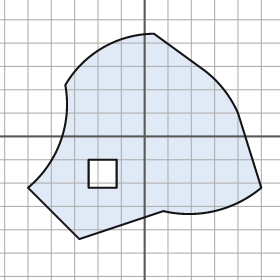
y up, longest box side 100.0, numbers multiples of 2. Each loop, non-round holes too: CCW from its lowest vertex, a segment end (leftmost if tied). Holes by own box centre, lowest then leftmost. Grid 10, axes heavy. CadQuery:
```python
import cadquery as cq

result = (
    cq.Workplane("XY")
    .moveTo(-28.0, -44.0)
    .lineTo(8.0, -32.0)
    .threePointArc((30.0, -32.0), (50.0, -22.0))
    .lineTo(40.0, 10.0)
    .threePointArc((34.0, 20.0), (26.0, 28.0))
    .lineTo(4.0, 44.0)
    .threePointArc((-18.0, 38.0), (-34.0, 22.0))
    .threePointArc((-36.0, -2.0), (-50.0, -22.0))
    .close()
    .moveTo(-24.0, -22.0)
    .lineTo(-12.0, -22.0)
    .lineTo(-12.0, -10.0)
    .lineTo(-24.0, -10.0)
    .close()
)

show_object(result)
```